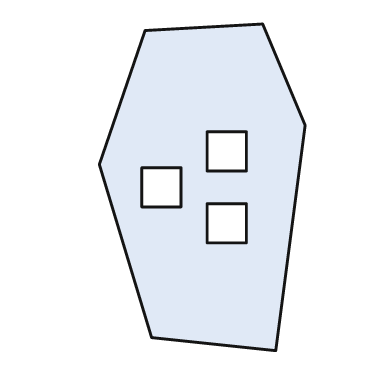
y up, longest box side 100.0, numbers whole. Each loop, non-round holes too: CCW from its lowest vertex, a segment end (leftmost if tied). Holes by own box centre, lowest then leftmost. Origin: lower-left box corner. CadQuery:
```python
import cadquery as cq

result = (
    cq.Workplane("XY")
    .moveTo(54.0, 0.0)
    .lineTo(63.0, 69.0)
    .lineTo(50.0, 100.0)
    .lineTo(14.0, 98.0)
    .lineTo(0.0, 57.0)
    .lineTo(16.0, 4.0)
    .close()
    .moveTo(33.0, 33.0)
    .lineTo(45.0, 33.0)
    .lineTo(45.0, 45.0)
    .lineTo(33.0, 45.0)
    .close()
    .moveTo(13.0, 44.0)
    .lineTo(25.0, 44.0)
    .lineTo(25.0, 56.0)
    .lineTo(13.0, 56.0)
    .close()
    .moveTo(33.0, 55.0)
    .lineTo(45.0, 55.0)
    .lineTo(45.0, 67.0)
    .lineTo(33.0, 67.0)
    .close()
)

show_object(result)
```